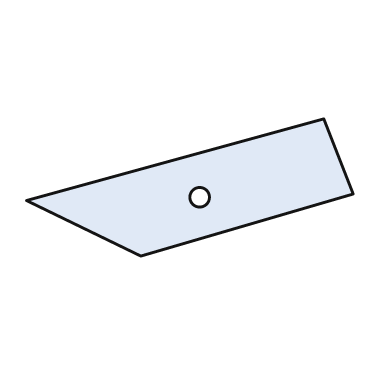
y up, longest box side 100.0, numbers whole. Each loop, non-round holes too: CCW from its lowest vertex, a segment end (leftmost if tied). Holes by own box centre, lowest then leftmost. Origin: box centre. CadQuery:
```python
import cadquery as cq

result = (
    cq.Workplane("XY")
    .moveTo(-15.0, -21.0)
    .lineTo(50.0, -2.0)
    .lineTo(41.0, 21.0)
    .lineTo(-50.0, -4.0)
    .close()
    .moveTo(3.0, -3.0)
    .circle(3.0)
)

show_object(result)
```